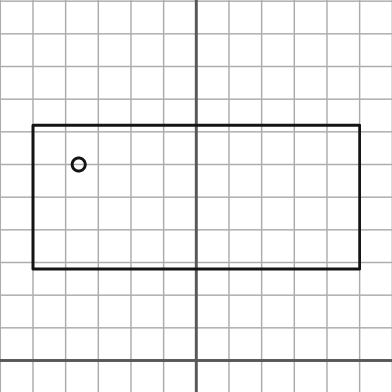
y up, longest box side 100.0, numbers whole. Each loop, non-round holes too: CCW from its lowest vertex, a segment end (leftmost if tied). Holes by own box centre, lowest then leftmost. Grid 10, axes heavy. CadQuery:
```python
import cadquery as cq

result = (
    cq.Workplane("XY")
    .moveTo(-50.0, 28.0)
    .lineTo(50.0, 28.0)
    .lineTo(50.0, 72.0)
    .lineTo(-50.0, 72.0)
    .close()
    .moveTo(-36.0, 60.0)
    .circle(2.0)
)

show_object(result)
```